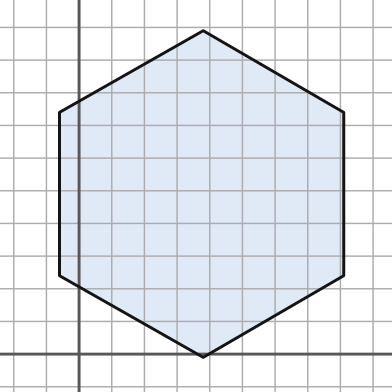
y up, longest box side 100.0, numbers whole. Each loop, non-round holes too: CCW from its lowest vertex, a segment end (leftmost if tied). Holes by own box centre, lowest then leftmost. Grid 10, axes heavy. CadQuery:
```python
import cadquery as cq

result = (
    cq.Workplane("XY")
    .moveTo(38.0, -1.0)
    .lineTo(81.0, 24.0)
    .lineTo(81.0, 74.0)
    .lineTo(38.0, 99.0)
    .lineTo(-6.0, 74.0)
    .lineTo(-6.0, 24.0)
    .close()
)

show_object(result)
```